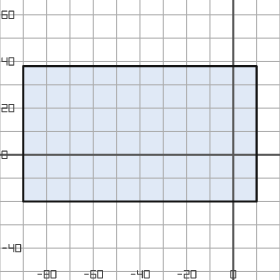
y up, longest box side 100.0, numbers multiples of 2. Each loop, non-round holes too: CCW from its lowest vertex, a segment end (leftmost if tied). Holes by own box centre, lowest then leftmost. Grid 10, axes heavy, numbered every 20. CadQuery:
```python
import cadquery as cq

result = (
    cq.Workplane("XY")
    .moveTo(-90.0, -20.0)
    .lineTo(10.0, -20.0)
    .lineTo(10.0, 38.0)
    .lineTo(-90.0, 38.0)
    .close()
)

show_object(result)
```